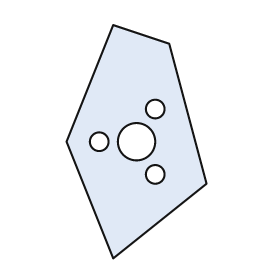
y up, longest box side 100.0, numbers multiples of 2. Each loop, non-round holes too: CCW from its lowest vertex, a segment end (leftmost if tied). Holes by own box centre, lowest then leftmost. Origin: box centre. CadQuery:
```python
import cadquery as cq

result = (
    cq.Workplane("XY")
    .moveTo(-10.0, -50.0)
    .lineTo(30.0, -18.0)
    .lineTo(14.0, 42.0)
    .lineTo(-10.0, 50.0)
    .lineTo(-30.0, 0.0)
    .close()
    .moveTo(8.0, -14.0)
    .circle(4.0)
    .moveTo(-16.0, 0.0)
    .circle(4.0)
    .moveTo(0.0, 0.0)
    .circle(8.0)
    .moveTo(8.0, 14.0)
    .circle(4.0)
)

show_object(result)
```